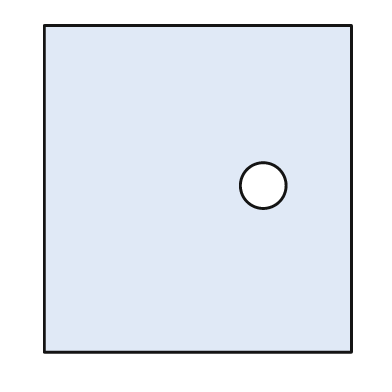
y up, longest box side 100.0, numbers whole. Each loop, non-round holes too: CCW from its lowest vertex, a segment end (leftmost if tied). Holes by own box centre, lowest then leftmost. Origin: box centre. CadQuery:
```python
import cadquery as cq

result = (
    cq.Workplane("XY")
    .moveTo(-47.0, -50.0)
    .lineTo(47.0, -50.0)
    .lineTo(47.0, 50.0)
    .lineTo(-47.0, 50.0)
    .close()
    .moveTo(20.0, 1.0)
    .circle(7.0)
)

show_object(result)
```